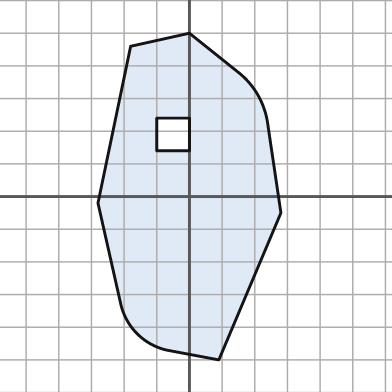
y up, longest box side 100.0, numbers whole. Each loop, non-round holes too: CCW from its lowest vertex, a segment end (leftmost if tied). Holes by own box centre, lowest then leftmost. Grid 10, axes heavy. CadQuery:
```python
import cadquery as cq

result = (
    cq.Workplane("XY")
    .moveTo(9.0, -50.0)
    .lineTo(28.0, -5.0)
    .lineTo(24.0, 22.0)
    .threePointArc((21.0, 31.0), (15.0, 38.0))
    .lineTo(0.0, 50.0)
    .lineTo(-18.0, 46.0)
    .lineTo(-28.0, -2.0)
    .lineTo(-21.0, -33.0)
    .threePointArc((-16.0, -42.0), (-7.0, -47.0))
    .close()
    .moveTo(-10.0, 14.0)
    .lineTo(0.0, 14.0)
    .lineTo(0.0, 24.0)
    .lineTo(-10.0, 24.0)
    .close()
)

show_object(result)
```